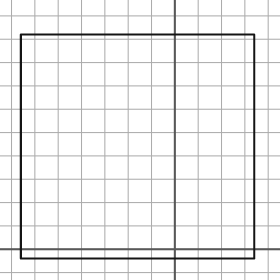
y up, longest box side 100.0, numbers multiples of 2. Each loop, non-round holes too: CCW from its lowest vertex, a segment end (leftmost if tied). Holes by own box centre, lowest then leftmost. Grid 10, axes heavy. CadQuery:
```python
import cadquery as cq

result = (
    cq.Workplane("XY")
    .moveTo(-66.0, -4.0)
    .lineTo(34.0, -4.0)
    .lineTo(34.0, 92.0)
    .lineTo(-66.0, 92.0)
    .close()
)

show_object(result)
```